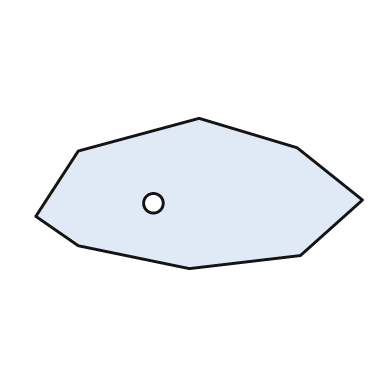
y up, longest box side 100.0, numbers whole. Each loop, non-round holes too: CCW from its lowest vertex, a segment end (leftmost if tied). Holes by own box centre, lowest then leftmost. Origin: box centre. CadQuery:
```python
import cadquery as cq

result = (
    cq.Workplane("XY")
    .moveTo(-3.0, -23.0)
    .lineTo(31.0, -19.0)
    .lineTo(50.0, -2.0)
    .lineTo(30.0, 14.0)
    .lineTo(0.0, 23.0)
    .lineTo(-37.0, 13.0)
    .lineTo(-50.0, -7.0)
    .lineTo(-37.0, -16.0)
    .close()
    .moveTo(-14.0, -3.0)
    .circle(3.0)
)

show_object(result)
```